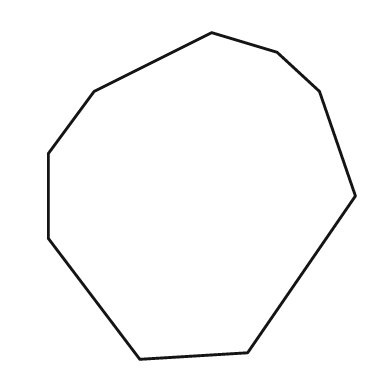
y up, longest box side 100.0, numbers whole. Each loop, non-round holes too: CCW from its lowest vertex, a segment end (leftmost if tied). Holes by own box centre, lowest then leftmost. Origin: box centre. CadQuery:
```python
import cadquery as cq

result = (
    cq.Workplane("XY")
    .moveTo(-19.0, -50.0)
    .lineTo(14.0, -48.0)
    .lineTo(47.0, 0.0)
    .lineTo(36.0, 32.0)
    .lineTo(23.0, 44.0)
    .lineTo(3.0, 50.0)
    .lineTo(-33.0, 32.0)
    .lineTo(-47.0, 13.0)
    .lineTo(-47.0, -13.0)
    .close()
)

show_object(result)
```